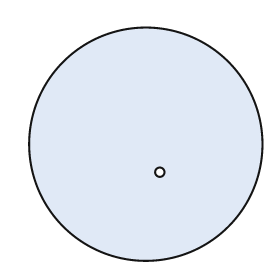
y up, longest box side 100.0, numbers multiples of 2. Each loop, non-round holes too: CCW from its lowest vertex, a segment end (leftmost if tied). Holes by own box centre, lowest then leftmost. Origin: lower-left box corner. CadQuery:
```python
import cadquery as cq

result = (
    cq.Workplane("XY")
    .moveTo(50.0, 50.0)
    .circle(50.0)
    .moveTo(56.0, 38.0)
    .circle(2.0)
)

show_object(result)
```